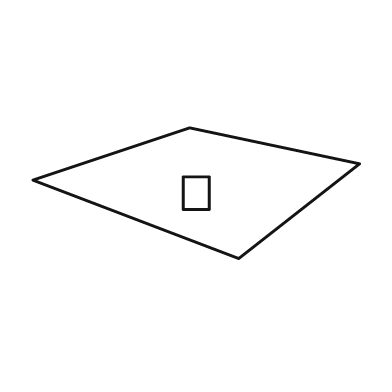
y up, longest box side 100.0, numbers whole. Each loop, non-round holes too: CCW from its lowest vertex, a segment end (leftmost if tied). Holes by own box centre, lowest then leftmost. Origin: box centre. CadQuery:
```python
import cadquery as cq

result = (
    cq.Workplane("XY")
    .moveTo(13.0, -20.0)
    .lineTo(50.0, 9.0)
    .lineTo(-2.0, 20.0)
    .lineTo(-50.0, 4.0)
    .close()
    .moveTo(-4.0, -5.0)
    .lineTo(4.0, -5.0)
    .lineTo(4.0, 5.0)
    .lineTo(-4.0, 5.0)
    .close()
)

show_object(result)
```